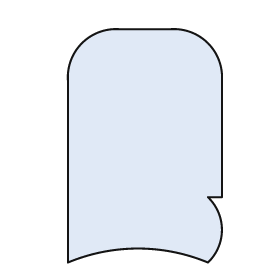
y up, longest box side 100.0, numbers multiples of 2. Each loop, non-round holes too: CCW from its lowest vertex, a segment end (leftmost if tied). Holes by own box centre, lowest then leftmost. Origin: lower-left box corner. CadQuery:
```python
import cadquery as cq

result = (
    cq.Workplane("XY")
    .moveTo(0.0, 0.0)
    .threePointArc((30.0, 6.0), (60.0, 0.0))
    .threePointArc((66.0, 14.0), (60.0, 28.0))
    .lineTo(66.0, 28.0)
    .lineTo(66.0, 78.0)
    .threePointArc((60.0, 94.0), (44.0, 100.0))
    .lineTo(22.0, 100.0)
    .threePointArc((6.0, 94.0), (0.0, 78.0))
    .close()
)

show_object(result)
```